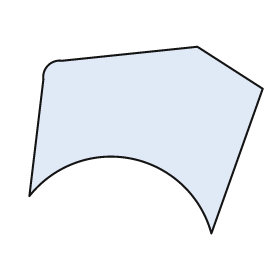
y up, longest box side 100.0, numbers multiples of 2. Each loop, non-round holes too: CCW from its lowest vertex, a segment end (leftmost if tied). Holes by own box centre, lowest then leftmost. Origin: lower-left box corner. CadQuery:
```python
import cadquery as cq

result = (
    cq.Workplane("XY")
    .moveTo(78.0, 0.0)
    .lineTo(100.0, 62.0)
    .lineTo(72.0, 80.0)
    .lineTo(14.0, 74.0)
    .threePointArc((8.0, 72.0), (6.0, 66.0))
    .lineTo(0.0, 16.0)
    .threePointArc((44.0, 32.0), (78.0, 0.0))
    .close()
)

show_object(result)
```